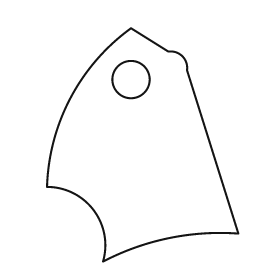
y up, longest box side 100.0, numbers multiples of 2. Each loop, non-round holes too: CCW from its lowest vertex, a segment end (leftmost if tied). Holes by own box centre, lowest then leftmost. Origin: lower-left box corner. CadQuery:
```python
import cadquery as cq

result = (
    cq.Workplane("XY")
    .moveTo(24.0, 0.0)
    .threePointArc((52.0, 10.0), (82.0, 12.0))
    .lineTo(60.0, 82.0)
    .threePointArc((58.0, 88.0), (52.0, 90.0))
    .lineTo(36.0, 100.0)
    .threePointArc((10.0, 70.0), (0.0, 32.0))
    .threePointArc((20.0, 22.0), (24.0, 0.0))
    .close()
    .moveTo(36.0, 78.0)
    .circle(8.0)
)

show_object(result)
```